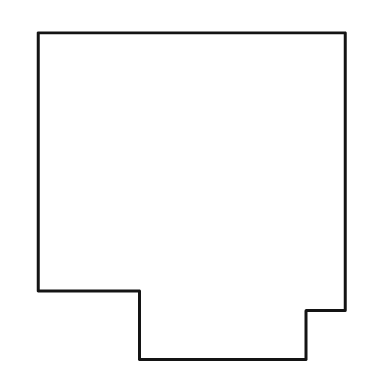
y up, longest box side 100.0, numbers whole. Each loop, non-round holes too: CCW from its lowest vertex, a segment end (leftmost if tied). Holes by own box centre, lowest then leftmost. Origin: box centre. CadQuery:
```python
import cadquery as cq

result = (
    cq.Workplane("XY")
    .moveTo(-16.0, -50.0)
    .lineTo(35.0, -50.0)
    .lineTo(35.0, -35.0)
    .lineTo(47.0, -35.0)
    .lineTo(47.0, 50.0)
    .lineTo(-47.0, 50.0)
    .lineTo(-47.0, -29.0)
    .lineTo(-16.0, -29.0)
    .close()
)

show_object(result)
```